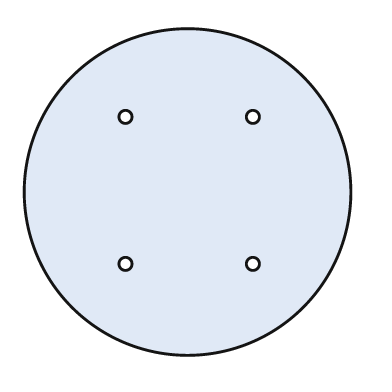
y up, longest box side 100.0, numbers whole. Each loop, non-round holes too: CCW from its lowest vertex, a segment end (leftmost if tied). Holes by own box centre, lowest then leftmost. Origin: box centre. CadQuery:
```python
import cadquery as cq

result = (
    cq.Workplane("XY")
    .moveTo(0.0, 0.0)
    .circle(50.0)
    .moveTo(-19.0, -22.0)
    .circle(2.0)
    .moveTo(20.0, -22.0)
    .circle(2.0)
    .moveTo(-19.0, 23.0)
    .circle(2.0)
    .moveTo(20.0, 23.0)
    .circle(2.0)
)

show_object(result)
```